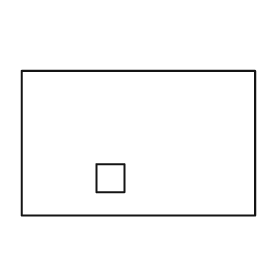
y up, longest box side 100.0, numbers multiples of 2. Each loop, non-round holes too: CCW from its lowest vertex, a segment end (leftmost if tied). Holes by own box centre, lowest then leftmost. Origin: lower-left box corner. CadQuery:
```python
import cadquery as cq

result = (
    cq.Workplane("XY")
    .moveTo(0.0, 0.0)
    .lineTo(100.0, 0.0)
    .lineTo(100.0, 62.0)
    .lineTo(0.0, 62.0)
    .close()
    .moveTo(32.0, 10.0)
    .lineTo(44.0, 10.0)
    .lineTo(44.0, 22.0)
    .lineTo(32.0, 22.0)
    .close()
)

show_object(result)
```